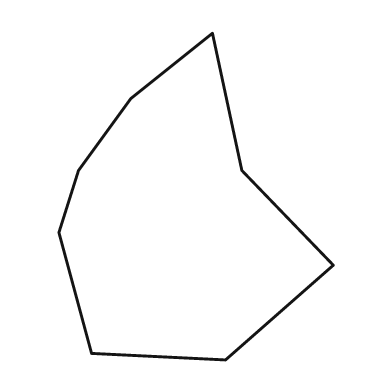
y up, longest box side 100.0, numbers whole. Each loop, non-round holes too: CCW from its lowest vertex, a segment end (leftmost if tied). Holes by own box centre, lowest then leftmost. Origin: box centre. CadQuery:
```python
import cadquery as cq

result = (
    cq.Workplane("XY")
    .moveTo(9.0, -50.0)
    .lineTo(42.0, -21.0)
    .lineTo(14.0, 8.0)
    .lineTo(5.0, 50.0)
    .lineTo(-20.0, 30.0)
    .lineTo(-36.0, 8.0)
    .lineTo(-42.0, -11.0)
    .lineTo(-32.0, -48.0)
    .close()
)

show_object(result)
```